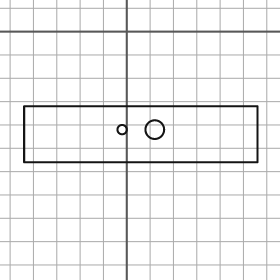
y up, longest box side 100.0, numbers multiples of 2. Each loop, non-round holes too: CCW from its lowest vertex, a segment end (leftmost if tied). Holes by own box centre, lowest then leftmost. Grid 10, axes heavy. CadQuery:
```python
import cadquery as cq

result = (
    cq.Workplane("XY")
    .moveTo(-44.0, -56.0)
    .lineTo(56.0, -56.0)
    .lineTo(56.0, -32.0)
    .lineTo(-44.0, -32.0)
    .close()
    .moveTo(-2.0, -42.0)
    .circle(2.0)
    .moveTo(12.0, -42.0)
    .circle(4.0)
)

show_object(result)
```